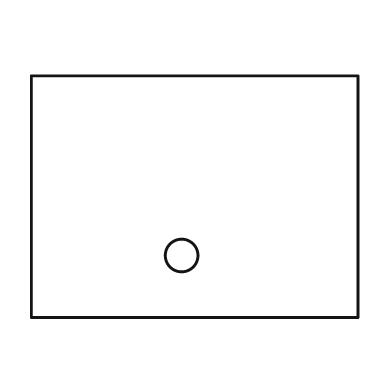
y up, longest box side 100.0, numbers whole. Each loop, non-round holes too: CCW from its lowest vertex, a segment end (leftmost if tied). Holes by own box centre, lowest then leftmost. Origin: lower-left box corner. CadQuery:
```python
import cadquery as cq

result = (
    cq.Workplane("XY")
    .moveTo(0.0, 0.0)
    .lineTo(100.0, 0.0)
    .lineTo(100.0, 74.0)
    .lineTo(0.0, 74.0)
    .close()
    .moveTo(46.0, 19.0)
    .circle(5.0)
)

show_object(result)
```